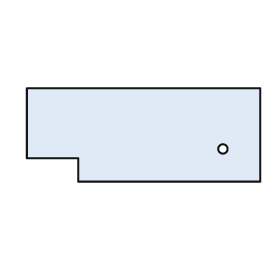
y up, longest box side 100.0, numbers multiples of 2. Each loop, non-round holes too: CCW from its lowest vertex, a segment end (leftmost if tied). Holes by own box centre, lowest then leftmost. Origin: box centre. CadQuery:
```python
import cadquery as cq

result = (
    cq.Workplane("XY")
    .moveTo(-28.0, -20.0)
    .lineTo(50.0, -20.0)
    .lineTo(50.0, 20.0)
    .lineTo(-50.0, 20.0)
    .lineTo(-50.0, -10.0)
    .lineTo(-28.0, -10.0)
    .close()
    .moveTo(34.0, -6.0)
    .circle(2.0)
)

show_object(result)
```